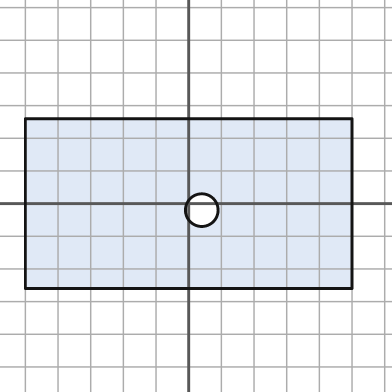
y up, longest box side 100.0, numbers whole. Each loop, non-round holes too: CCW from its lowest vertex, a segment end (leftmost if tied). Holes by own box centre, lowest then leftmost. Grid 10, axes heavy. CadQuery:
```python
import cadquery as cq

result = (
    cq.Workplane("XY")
    .moveTo(-50.0, -26.0)
    .lineTo(50.0, -26.0)
    .lineTo(50.0, 26.0)
    .lineTo(-50.0, 26.0)
    .close()
    .moveTo(4.0, -2.0)
    .circle(5.0)
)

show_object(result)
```